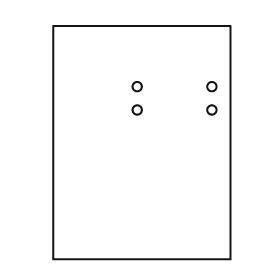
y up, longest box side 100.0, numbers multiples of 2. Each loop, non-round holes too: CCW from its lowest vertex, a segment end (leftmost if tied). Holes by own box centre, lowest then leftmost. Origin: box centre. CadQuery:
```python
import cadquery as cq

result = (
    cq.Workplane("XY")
    .moveTo(-38.0, -50.0)
    .lineTo(38.0, -50.0)
    .lineTo(38.0, 50.0)
    .lineTo(-38.0, 50.0)
    .close()
    .moveTo(-2.0, 14.0)
    .circle(2.0)
    .moveTo(30.0, 14.0)
    .circle(2.0)
    .moveTo(-2.0, 24.0)
    .circle(2.0)
    .moveTo(30.0, 24.0)
    .circle(2.0)
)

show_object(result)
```